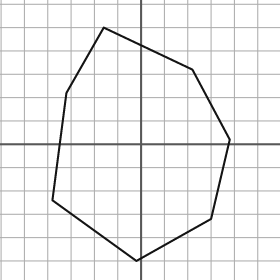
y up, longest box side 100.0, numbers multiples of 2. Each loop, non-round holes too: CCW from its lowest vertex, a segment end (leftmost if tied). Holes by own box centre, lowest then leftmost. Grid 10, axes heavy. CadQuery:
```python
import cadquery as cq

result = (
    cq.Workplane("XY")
    .moveTo(-2.0, -50.0)
    .lineTo(30.0, -32.0)
    .lineTo(38.0, 2.0)
    .lineTo(22.0, 32.0)
    .lineTo(-16.0, 50.0)
    .lineTo(-32.0, 22.0)
    .lineTo(-38.0, -24.0)
    .close()
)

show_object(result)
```